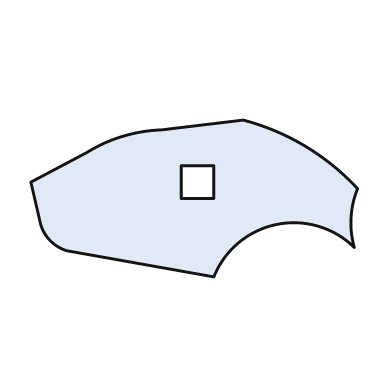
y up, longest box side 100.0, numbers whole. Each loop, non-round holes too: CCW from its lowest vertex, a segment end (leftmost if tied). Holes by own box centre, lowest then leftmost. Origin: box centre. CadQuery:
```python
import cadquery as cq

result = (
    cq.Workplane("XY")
    .moveTo(6.0, -24.0)
    .threePointArc((25.0, -8.0), (49.0, -15.0))
    .threePointArc((48.0, -6.0), (50.0, 3.0))
    .threePointArc((34.0, 16.0), (15.0, 24.0))
    .lineTo(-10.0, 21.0)
    .threePointArc((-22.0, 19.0), (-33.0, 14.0))
    .lineTo(-50.0, 5.0)
    .lineTo(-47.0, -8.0)
    .threePointArc((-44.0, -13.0), (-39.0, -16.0))
    .close()
    .moveTo(-4.0, 0.0)
    .lineTo(6.0, 0.0)
    .lineTo(6.0, 10.0)
    .lineTo(-4.0, 10.0)
    .close()
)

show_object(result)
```